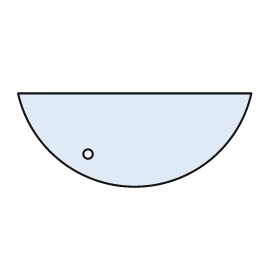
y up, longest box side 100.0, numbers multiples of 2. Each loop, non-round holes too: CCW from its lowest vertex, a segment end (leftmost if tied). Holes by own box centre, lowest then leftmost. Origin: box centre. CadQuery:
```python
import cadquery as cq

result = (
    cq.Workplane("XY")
    .moveTo(-50.0, 20.0)
    .threePointArc((0.0, -20.0), (50.0, 20.0))
    .close()
    .moveTo(-20.0, -6.0)
    .circle(2.0)
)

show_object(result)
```